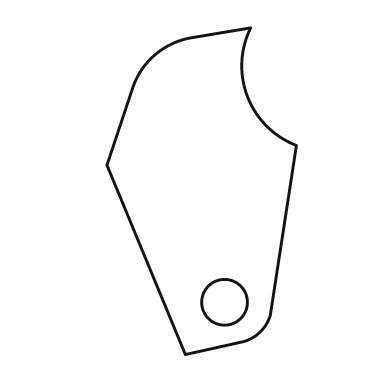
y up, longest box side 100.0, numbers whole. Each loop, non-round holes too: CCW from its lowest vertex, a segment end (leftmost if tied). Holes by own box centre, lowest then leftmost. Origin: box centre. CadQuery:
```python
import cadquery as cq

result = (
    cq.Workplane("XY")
    .moveTo(-5.0, -50.0)
    .lineTo(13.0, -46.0)
    .threePointArc((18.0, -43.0), (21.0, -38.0))
    .lineTo(29.0, 14.0)
    .threePointArc((14.0, 29.0), (15.0, 50.0))
    .lineTo(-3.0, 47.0)
    .threePointArc((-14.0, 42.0), (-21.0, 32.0))
    .lineTo(-29.0, 8.0)
    .close()
    .moveTo(7.0, -34.0)
    .circle(7.0)
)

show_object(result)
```